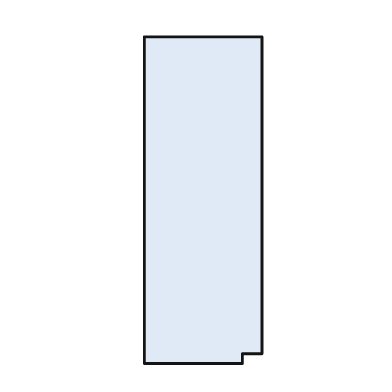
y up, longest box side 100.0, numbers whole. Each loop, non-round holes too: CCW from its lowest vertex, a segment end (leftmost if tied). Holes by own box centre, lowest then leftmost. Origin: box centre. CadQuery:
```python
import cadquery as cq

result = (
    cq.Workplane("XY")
    .moveTo(-18.0, -50.0)
    .lineTo(12.0, -50.0)
    .lineTo(12.0, -47.0)
    .lineTo(18.0, -47.0)
    .lineTo(18.0, 50.0)
    .lineTo(-18.0, 50.0)
    .close()
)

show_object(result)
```